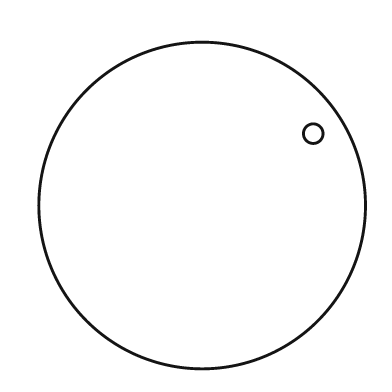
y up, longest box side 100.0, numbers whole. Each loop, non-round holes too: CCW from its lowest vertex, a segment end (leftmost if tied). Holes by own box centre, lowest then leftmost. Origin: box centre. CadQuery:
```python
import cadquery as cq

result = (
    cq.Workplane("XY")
    .moveTo(0.0, 0.0)
    .circle(50.0)
    .moveTo(34.0, 22.0)
    .circle(3.0)
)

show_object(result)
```